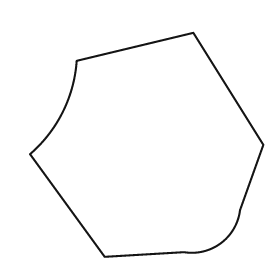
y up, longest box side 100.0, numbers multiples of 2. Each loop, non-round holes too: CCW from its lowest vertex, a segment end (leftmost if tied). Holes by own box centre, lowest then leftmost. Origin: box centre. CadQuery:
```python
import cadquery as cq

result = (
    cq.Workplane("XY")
    .moveTo(-18.0, -48.0)
    .lineTo(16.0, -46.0)
    .threePointArc((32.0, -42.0), (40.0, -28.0))
    .lineTo(50.0, 0.0)
    .lineTo(20.0, 48.0)
    .lineTo(-30.0, 36.0)
    .threePointArc((-36.0, 14.0), (-50.0, -4.0))
    .close()
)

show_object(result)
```